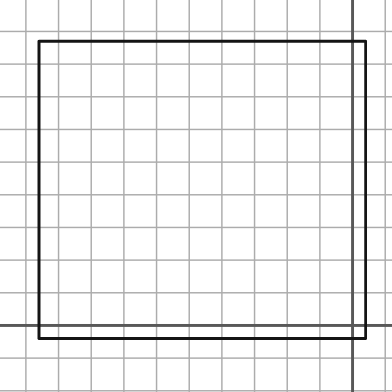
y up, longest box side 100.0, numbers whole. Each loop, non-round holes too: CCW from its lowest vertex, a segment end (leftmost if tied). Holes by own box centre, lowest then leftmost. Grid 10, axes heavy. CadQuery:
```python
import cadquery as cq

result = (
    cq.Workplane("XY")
    .moveTo(-96.0, -4.0)
    .lineTo(4.0, -4.0)
    .lineTo(4.0, 87.0)
    .lineTo(-96.0, 87.0)
    .close()
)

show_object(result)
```